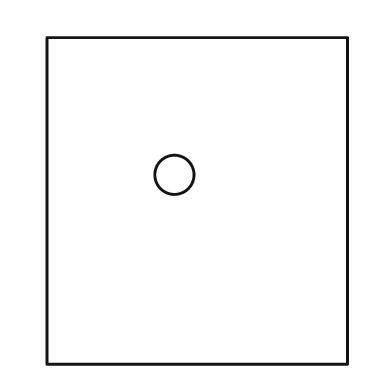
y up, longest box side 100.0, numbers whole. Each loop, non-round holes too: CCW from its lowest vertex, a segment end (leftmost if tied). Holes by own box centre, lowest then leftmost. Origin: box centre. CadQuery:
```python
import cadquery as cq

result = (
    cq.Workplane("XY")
    .moveTo(-46.0, -50.0)
    .lineTo(46.0, -50.0)
    .lineTo(46.0, 50.0)
    .lineTo(-46.0, 50.0)
    .close()
    .moveTo(-7.0, 8.0)
    .circle(6.0)
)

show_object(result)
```